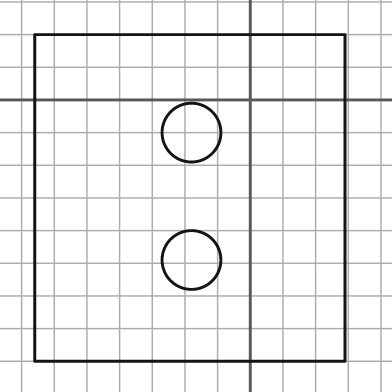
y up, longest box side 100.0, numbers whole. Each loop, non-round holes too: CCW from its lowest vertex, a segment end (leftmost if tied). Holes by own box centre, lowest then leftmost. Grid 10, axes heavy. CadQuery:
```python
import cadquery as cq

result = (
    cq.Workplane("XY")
    .moveTo(-66.0, -80.0)
    .lineTo(29.0, -80.0)
    .lineTo(29.0, 20.0)
    .lineTo(-66.0, 20.0)
    .close()
    .moveTo(-18.0, -49.0)
    .circle(9.0)
    .moveTo(-18.0, -10.0)
    .circle(9.0)
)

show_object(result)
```